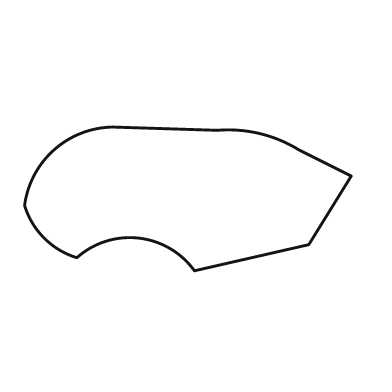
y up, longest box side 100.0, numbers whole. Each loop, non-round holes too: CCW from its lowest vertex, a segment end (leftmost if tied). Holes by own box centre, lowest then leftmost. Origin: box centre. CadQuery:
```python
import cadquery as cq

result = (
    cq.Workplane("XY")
    .moveTo(2.0, -22.0)
    .lineTo(37.0, -14.0)
    .lineTo(50.0, 7.0)
    .lineTo(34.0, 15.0)
    .threePointArc((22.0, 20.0), (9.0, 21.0))
    .lineTo(-23.0, 22.0)
    .threePointArc((-41.0, 15.0), (-50.0, -2.0))
    .threePointArc((-44.0, -12.0), (-34.0, -18.0))
    .threePointArc((-15.0, -12.0), (2.0, -22.0))
    .close()
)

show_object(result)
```